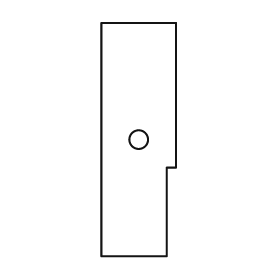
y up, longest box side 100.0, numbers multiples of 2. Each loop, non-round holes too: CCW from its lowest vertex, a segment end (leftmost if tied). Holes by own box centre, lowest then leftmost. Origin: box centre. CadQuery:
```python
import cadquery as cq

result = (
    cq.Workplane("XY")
    .moveTo(-16.0, -50.0)
    .lineTo(12.0, -50.0)
    .lineTo(12.0, -12.0)
    .lineTo(16.0, -12.0)
    .lineTo(16.0, 50.0)
    .lineTo(-16.0, 50.0)
    .close()
    .moveTo(0.0, 0.0)
    .circle(4.0)
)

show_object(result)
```